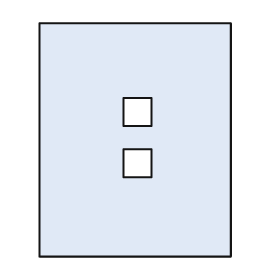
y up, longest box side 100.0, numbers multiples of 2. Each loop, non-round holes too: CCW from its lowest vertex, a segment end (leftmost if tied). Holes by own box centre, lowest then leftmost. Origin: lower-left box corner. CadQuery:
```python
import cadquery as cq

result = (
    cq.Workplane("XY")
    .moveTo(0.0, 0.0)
    .lineTo(82.0, 0.0)
    .lineTo(82.0, 100.0)
    .lineTo(0.0, 100.0)
    .close()
    .moveTo(36.0, 34.0)
    .lineTo(48.0, 34.0)
    .lineTo(48.0, 46.0)
    .lineTo(36.0, 46.0)
    .close()
    .moveTo(36.0, 56.0)
    .lineTo(48.0, 56.0)
    .lineTo(48.0, 68.0)
    .lineTo(36.0, 68.0)
    .close()
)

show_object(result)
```